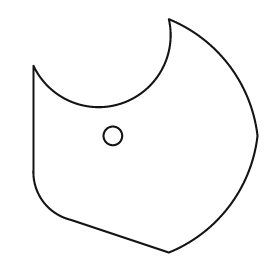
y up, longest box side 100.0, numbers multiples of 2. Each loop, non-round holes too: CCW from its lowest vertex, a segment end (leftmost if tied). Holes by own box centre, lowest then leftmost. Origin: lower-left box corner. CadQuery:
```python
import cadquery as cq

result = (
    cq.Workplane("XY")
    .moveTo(58.0, 0.0)
    .threePointArc((84.0, 20.0), (96.0, 50.0))
    .threePointArc((84.0, 80.0), (58.0, 100.0))
    .threePointArc((38.0, 64.0), (0.0, 80.0))
    .lineTo(0.0, 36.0)
    .threePointArc((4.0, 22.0), (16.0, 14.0))
    .close()
    .moveTo(34.0, 50.0)
    .circle(4.0)
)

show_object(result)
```